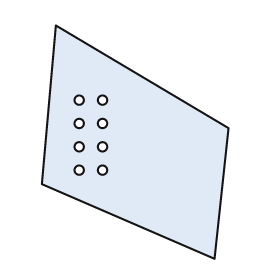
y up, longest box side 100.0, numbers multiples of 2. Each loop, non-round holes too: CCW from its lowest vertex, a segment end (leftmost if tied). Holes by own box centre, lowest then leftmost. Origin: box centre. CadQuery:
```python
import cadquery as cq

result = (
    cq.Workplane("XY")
    .moveTo(34.0, -50.0)
    .lineTo(40.0, 6.0)
    .lineTo(-34.0, 50.0)
    .lineTo(-40.0, -18.0)
    .close()
    .moveTo(-24.0, -12.0)
    .circle(2.0)
    .moveTo(-14.0, -12.0)
    .circle(2.0)
    .moveTo(-24.0, -2.0)
    .circle(2.0)
    .moveTo(-14.0, -2.0)
    .circle(2.0)
    .moveTo(-24.0, 8.0)
    .circle(2.0)
    .moveTo(-14.0, 8.0)
    .circle(2.0)
    .moveTo(-24.0, 18.0)
    .circle(2.0)
    .moveTo(-14.0, 18.0)
    .circle(2.0)
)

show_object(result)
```